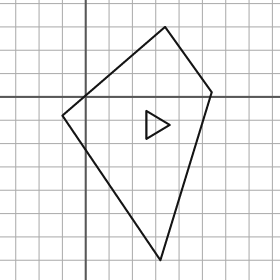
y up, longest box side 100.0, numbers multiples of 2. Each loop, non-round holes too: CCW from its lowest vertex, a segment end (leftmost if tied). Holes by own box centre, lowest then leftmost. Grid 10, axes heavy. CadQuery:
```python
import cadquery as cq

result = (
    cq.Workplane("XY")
    .moveTo(32.0, -70.0)
    .lineTo(54.0, 2.0)
    .lineTo(34.0, 30.0)
    .lineTo(-10.0, -8.0)
    .close()
    .moveTo(26.0, -18.0)
    .lineTo(36.0, -12.0)
    .lineTo(26.0, -6.0)
    .close()
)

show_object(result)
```